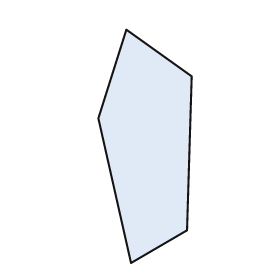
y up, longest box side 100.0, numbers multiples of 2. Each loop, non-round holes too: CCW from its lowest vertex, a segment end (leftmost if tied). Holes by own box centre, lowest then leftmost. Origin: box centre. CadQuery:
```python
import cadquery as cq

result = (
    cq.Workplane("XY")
    .moveTo(-6.0, -50.0)
    .lineTo(18.0, -36.0)
    .lineTo(20.0, 30.0)
    .lineTo(-8.0, 50.0)
    .lineTo(-20.0, 12.0)
    .close()
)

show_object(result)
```